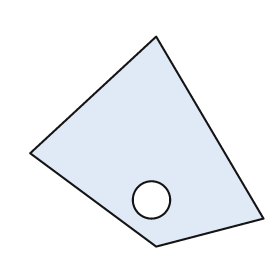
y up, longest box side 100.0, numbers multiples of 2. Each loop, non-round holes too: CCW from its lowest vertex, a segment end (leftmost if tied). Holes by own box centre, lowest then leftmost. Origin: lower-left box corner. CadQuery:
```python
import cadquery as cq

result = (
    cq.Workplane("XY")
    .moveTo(54.0, 0.0)
    .lineTo(100.0, 12.0)
    .lineTo(54.0, 90.0)
    .lineTo(0.0, 40.0)
    .close()
    .moveTo(52.0, 20.0)
    .circle(8.0)
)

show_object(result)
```